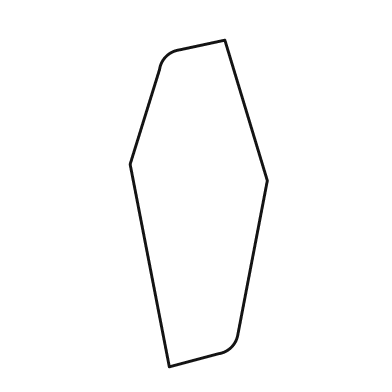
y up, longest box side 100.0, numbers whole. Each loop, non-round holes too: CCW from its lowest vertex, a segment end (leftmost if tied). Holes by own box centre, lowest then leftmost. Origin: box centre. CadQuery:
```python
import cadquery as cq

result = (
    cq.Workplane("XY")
    .moveTo(-9.0, -50.0)
    .lineTo(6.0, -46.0)
    .threePointArc((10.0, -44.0), (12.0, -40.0))
    .lineTo(21.0, 7.0)
    .lineTo(8.0, 50.0)
    .lineTo(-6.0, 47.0)
    .threePointArc((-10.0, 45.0), (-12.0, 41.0))
    .lineTo(-21.0, 12.0)
    .close()
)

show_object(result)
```